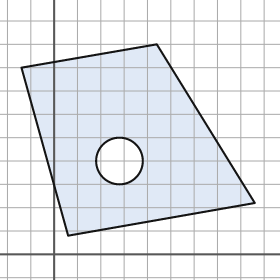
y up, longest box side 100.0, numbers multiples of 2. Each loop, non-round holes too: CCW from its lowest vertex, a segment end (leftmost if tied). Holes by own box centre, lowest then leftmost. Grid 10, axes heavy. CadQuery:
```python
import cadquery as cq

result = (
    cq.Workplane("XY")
    .moveTo(6.0, 8.0)
    .lineTo(86.0, 22.0)
    .lineTo(44.0, 90.0)
    .lineTo(-14.0, 80.0)
    .close()
    .moveTo(28.0, 40.0)
    .circle(10.0)
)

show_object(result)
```